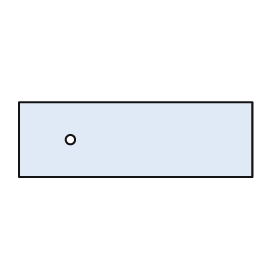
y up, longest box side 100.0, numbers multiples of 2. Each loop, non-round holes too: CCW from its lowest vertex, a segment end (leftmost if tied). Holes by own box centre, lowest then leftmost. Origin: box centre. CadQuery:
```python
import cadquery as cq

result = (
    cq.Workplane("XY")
    .moveTo(-50.0, -16.0)
    .lineTo(50.0, -16.0)
    .lineTo(50.0, 16.0)
    .lineTo(-50.0, 16.0)
    .close()
    .moveTo(-28.0, 0.0)
    .circle(2.0)
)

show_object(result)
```